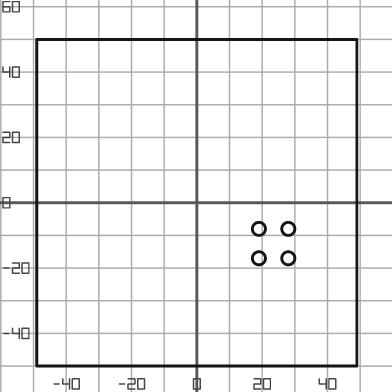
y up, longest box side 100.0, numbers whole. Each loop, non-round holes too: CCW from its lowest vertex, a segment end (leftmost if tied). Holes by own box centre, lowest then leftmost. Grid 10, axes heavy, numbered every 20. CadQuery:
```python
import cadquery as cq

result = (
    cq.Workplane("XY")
    .moveTo(-49.0, -50.0)
    .lineTo(49.0, -50.0)
    .lineTo(49.0, 50.0)
    .lineTo(-49.0, 50.0)
    .close()
    .moveTo(19.0, -17.0)
    .circle(2.0)
    .moveTo(28.0, -17.0)
    .circle(2.0)
    .moveTo(19.0, -8.0)
    .circle(2.0)
    .moveTo(28.0, -8.0)
    .circle(2.0)
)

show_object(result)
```